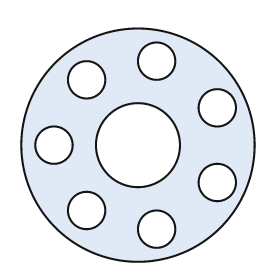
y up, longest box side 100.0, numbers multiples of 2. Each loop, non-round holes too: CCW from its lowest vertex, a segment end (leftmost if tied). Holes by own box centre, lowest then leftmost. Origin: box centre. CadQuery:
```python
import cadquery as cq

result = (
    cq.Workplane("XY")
    .moveTo(0.0, 0.0)
    .circle(50.0)
    .moveTo(8.0, -36.0)
    .circle(8.0)
    .moveTo(-22.0, -28.0)
    .circle(8.0)
    .moveTo(34.0, -16.0)
    .circle(8.0)
    .moveTo(-36.0, 0.0)
    .circle(8.0)
    .moveTo(0.0, 0.0)
    .circle(18.0)
    .moveTo(34.0, 16.0)
    .circle(8.0)
    .moveTo(-22.0, 28.0)
    .circle(8.0)
    .moveTo(8.0, 36.0)
    .circle(8.0)
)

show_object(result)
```